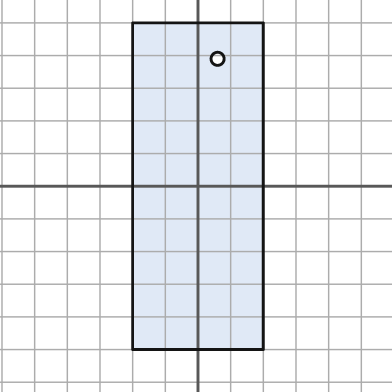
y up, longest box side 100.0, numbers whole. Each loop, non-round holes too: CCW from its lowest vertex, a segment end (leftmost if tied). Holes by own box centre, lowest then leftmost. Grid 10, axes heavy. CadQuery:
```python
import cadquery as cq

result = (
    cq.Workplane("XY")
    .moveTo(-20.0, -50.0)
    .lineTo(20.0, -50.0)
    .lineTo(20.0, 50.0)
    .lineTo(-20.0, 50.0)
    .close()
    .moveTo(6.0, 39.0)
    .circle(2.0)
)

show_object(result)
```